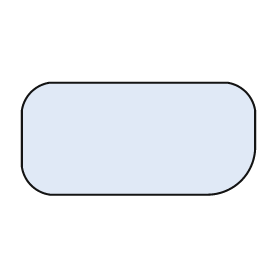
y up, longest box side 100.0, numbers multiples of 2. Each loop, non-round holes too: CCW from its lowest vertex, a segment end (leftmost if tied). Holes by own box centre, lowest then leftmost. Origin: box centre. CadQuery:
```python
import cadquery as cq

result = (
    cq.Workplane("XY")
    .moveTo(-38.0, -24.0)
    .lineTo(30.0, -24.0)
    .threePointArc((44.0, -18.0), (50.0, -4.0))
    .lineTo(50.0, 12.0)
    .threePointArc((46.0, 20.0), (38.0, 24.0))
    .lineTo(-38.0, 24.0)
    .threePointArc((-46.0, 20.0), (-50.0, 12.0))
    .lineTo(-50.0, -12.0)
    .threePointArc((-46.0, -20.0), (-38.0, -24.0))
    .close()
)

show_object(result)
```